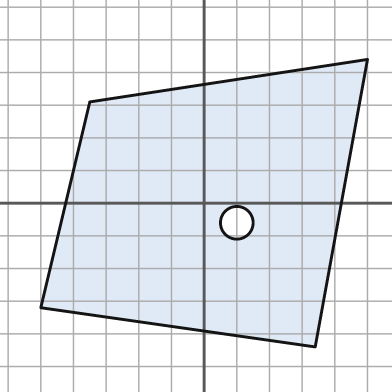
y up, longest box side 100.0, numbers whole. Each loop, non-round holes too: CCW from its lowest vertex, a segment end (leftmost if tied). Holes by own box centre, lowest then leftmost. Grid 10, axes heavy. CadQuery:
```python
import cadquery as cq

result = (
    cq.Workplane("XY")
    .moveTo(34.0, -44.0)
    .lineTo(50.0, 44.0)
    .lineTo(-35.0, 31.0)
    .lineTo(-50.0, -32.0)
    .close()
    .moveTo(10.0, -6.0)
    .circle(5.0)
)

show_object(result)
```